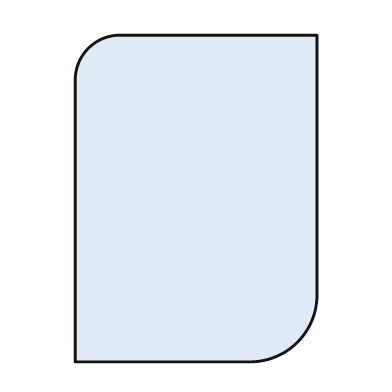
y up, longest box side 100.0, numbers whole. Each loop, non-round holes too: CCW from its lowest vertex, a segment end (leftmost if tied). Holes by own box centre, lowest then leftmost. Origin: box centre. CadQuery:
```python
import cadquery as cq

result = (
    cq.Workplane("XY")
    .moveTo(-37.0, -50.0)
    .lineTo(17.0, -50.0)
    .threePointArc((31.0, -44.0), (37.0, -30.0))
    .lineTo(37.0, 50.0)
    .lineTo(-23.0, 50.0)
    .threePointArc((-33.0, 46.0), (-37.0, 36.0))
    .close()
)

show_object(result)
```